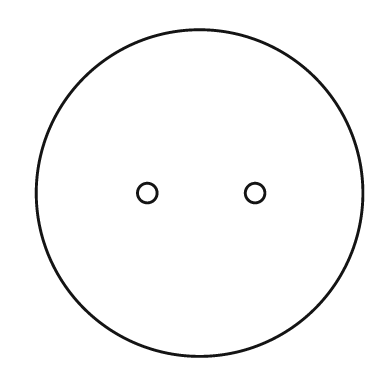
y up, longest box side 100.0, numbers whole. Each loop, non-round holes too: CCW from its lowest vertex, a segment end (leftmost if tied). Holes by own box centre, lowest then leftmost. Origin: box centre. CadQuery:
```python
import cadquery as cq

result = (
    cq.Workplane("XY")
    .moveTo(0.0, 0.0)
    .circle(50.0)
    .moveTo(-16.0, 0.0)
    .circle(3.0)
    .moveTo(17.0, 0.0)
    .circle(3.0)
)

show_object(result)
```